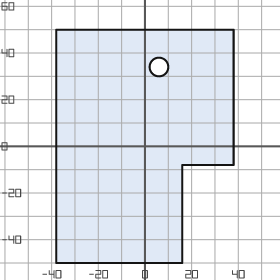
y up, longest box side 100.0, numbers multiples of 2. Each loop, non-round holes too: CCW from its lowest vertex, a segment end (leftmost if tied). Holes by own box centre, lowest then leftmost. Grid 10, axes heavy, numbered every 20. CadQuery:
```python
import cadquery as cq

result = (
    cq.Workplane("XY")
    .moveTo(-38.0, -50.0)
    .lineTo(16.0, -50.0)
    .lineTo(16.0, -8.0)
    .lineTo(38.0, -8.0)
    .lineTo(38.0, 50.0)
    .lineTo(-38.0, 50.0)
    .close()
    .moveTo(6.0, 34.0)
    .circle(4.0)
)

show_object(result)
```